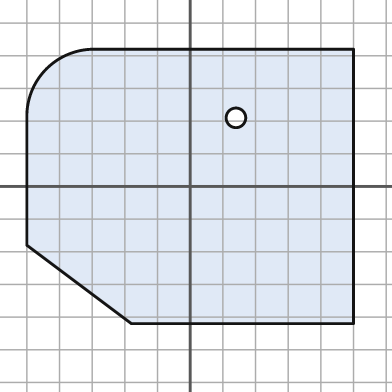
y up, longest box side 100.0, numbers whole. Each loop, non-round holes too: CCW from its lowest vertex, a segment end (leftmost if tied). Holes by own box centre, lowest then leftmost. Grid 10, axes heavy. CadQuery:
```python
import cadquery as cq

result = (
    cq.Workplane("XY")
    .moveTo(-18.0, -42.0)
    .lineTo(50.0, -42.0)
    .lineTo(50.0, 42.0)
    .lineTo(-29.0, 42.0)
    .threePointArc((-44.0, 36.0), (-50.0, 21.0))
    .lineTo(-50.0, -18.0)
    .close()
    .moveTo(14.0, 21.0)
    .circle(3.0)
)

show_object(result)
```